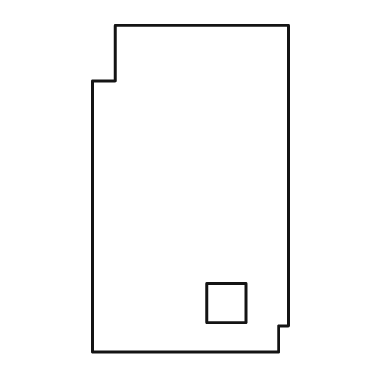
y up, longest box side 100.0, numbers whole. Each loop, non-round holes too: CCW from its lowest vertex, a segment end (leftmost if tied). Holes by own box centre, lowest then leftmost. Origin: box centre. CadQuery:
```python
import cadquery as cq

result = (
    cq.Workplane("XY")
    .moveTo(-30.0, -50.0)
    .lineTo(27.0, -50.0)
    .lineTo(27.0, -42.0)
    .lineTo(30.0, -42.0)
    .lineTo(30.0, 50.0)
    .lineTo(-23.0, 50.0)
    .lineTo(-23.0, 33.0)
    .lineTo(-30.0, 33.0)
    .close()
    .moveTo(5.0, -41.0)
    .lineTo(17.0, -41.0)
    .lineTo(17.0, -29.0)
    .lineTo(5.0, -29.0)
    .close()
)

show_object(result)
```